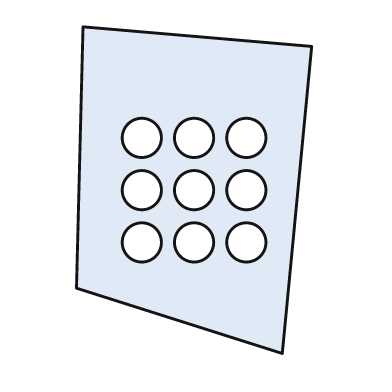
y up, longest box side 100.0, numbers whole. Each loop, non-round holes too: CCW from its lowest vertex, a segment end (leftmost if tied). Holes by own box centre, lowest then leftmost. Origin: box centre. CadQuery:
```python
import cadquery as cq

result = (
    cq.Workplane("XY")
    .moveTo(27.0, -50.0)
    .lineTo(36.0, 44.0)
    .lineTo(-34.0, 50.0)
    .lineTo(-36.0, -30.0)
    .close()
    .moveTo(-16.0, -16.0)
    .circle(6.0)
    .moveTo(0.0, -16.0)
    .circle(6.0)
    .moveTo(16.0, -16.0)
    .circle(6.0)
    .moveTo(-16.0, 0.0)
    .circle(6.0)
    .moveTo(0.0, 0.0)
    .circle(6.0)
    .moveTo(16.0, 0.0)
    .circle(6.0)
    .moveTo(-16.0, 16.0)
    .circle(6.0)
    .moveTo(0.0, 16.0)
    .circle(6.0)
    .moveTo(16.0, 16.0)
    .circle(6.0)
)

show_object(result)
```